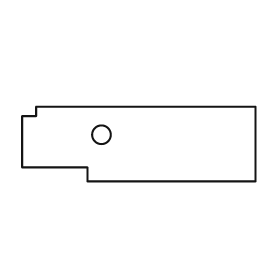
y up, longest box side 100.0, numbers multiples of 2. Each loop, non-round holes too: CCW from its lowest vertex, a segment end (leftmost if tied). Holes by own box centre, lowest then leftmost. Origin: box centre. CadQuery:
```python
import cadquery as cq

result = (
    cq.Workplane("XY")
    .moveTo(-22.0, -16.0)
    .lineTo(50.0, -16.0)
    .lineTo(50.0, 16.0)
    .lineTo(-44.0, 16.0)
    .lineTo(-44.0, 12.0)
    .lineTo(-50.0, 12.0)
    .lineTo(-50.0, -10.0)
    .lineTo(-22.0, -10.0)
    .close()
    .moveTo(-16.0, 4.0)
    .circle(4.0)
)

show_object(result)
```